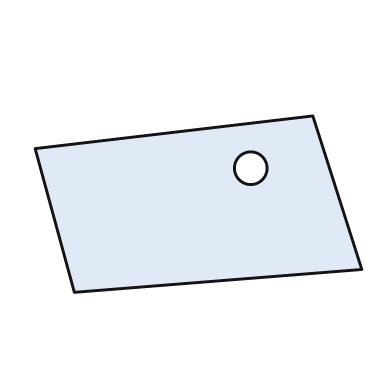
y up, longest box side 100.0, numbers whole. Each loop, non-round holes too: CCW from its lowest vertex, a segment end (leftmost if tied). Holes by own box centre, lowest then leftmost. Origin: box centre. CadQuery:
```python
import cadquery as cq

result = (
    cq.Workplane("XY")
    .moveTo(-38.0, -27.0)
    .lineTo(50.0, -20.0)
    .lineTo(35.0, 27.0)
    .lineTo(-50.0, 17.0)
    .close()
    .moveTo(16.0, 11.0)
    .circle(5.0)
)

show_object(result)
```